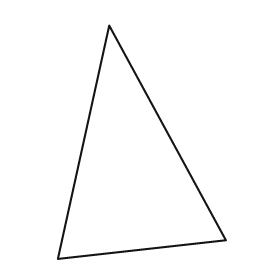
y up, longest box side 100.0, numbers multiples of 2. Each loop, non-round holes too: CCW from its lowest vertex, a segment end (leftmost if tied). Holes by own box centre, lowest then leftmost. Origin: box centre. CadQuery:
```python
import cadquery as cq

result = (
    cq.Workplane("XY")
    .moveTo(-36.0, -50.0)
    .lineTo(36.0, -42.0)
    .lineTo(-14.0, 50.0)
    .close()
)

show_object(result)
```